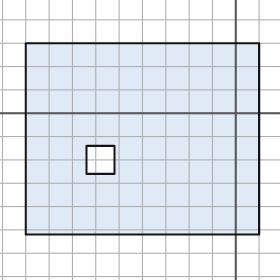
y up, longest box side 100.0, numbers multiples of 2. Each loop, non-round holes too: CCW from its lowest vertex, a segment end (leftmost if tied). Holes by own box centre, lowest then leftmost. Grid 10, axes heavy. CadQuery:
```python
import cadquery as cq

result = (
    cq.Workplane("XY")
    .moveTo(-90.0, -52.0)
    .lineTo(10.0, -52.0)
    .lineTo(10.0, 30.0)
    .lineTo(-90.0, 30.0)
    .close()
    .moveTo(-64.0, -26.0)
    .lineTo(-52.0, -26.0)
    .lineTo(-52.0, -14.0)
    .lineTo(-64.0, -14.0)
    .close()
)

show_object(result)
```